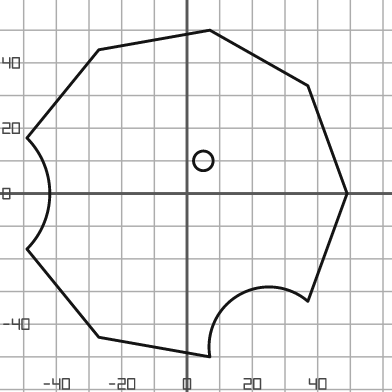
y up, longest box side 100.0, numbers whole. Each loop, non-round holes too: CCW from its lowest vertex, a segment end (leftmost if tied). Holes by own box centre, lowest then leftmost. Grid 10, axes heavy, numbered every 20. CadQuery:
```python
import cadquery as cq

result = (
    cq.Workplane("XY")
    .moveTo(7.0, -50.0)
    .threePointArc((16.0, -31.0), (37.0, -33.0))
    .lineTo(49.0, 0.0)
    .lineTo(37.0, 33.0)
    .lineTo(7.0, 50.0)
    .lineTo(-27.0, 44.0)
    .lineTo(-49.0, 17.0)
    .threePointArc((-42.0, 0.0), (-49.0, -17.0))
    .lineTo(-27.0, -44.0)
    .close()
    .moveTo(5.0, 10.0)
    .circle(3.0)
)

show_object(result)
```